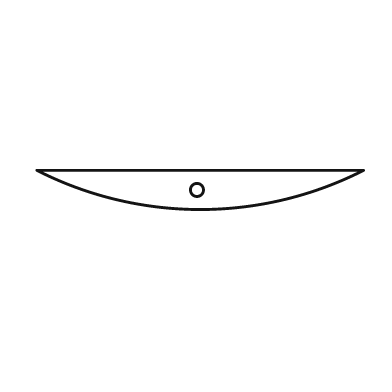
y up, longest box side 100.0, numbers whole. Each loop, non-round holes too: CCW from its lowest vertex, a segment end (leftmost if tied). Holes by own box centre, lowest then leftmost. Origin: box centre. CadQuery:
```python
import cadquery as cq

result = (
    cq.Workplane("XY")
    .moveTo(-50.0, 6.0)
    .threePointArc((0.0, -6.0), (50.0, 6.0))
    .close()
    .moveTo(-1.0, 0.0)
    .circle(2.0)
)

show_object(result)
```